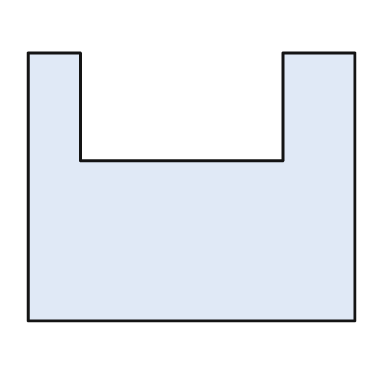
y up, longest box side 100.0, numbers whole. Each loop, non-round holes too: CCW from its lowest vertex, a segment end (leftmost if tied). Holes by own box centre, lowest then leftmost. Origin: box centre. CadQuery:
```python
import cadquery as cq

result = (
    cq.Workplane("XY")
    .moveTo(-50.0, -41.0)
    .lineTo(50.0, -41.0)
    .lineTo(50.0, 41.0)
    .lineTo(28.0, 41.0)
    .lineTo(28.0, 8.0)
    .lineTo(-34.0, 8.0)
    .lineTo(-34.0, 41.0)
    .lineTo(-50.0, 41.0)
    .close()
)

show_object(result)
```